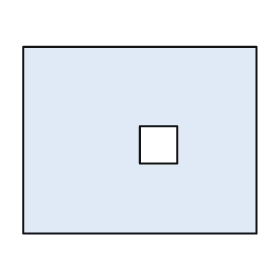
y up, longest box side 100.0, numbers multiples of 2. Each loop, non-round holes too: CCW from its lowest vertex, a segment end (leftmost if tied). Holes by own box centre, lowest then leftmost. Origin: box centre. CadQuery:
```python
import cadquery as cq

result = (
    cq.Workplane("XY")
    .moveTo(-50.0, -40.0)
    .lineTo(50.0, -40.0)
    .lineTo(50.0, 40.0)
    .lineTo(-50.0, 40.0)
    .close()
    .moveTo(0.0, -10.0)
    .lineTo(16.0, -10.0)
    .lineTo(16.0, 6.0)
    .lineTo(0.0, 6.0)
    .close()
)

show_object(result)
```